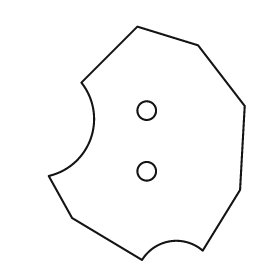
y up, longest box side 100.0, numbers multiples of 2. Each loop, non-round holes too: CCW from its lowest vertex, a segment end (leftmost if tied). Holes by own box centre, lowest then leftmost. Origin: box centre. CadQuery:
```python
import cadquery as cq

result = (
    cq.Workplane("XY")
    .moveTo(-2.0, -50.0)
    .threePointArc((10.0, -42.0), (24.0, -46.0))
    .lineTo(40.0, -20.0)
    .lineTo(42.0, 16.0)
    .lineTo(22.0, 42.0)
    .lineTo(-4.0, 50.0)
    .lineTo(-28.0, 26.0)
    .threePointArc((-24.0, 2.0), (-42.0, -14.0))
    .lineTo(-32.0, -32.0)
    .close()
    .moveTo(0.0, -12.0)
    .circle(4.0)
    .moveTo(0.0, 14.0)
    .circle(4.0)
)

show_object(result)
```